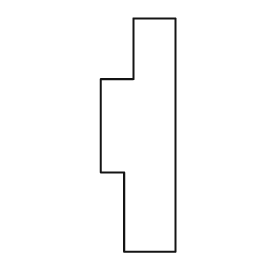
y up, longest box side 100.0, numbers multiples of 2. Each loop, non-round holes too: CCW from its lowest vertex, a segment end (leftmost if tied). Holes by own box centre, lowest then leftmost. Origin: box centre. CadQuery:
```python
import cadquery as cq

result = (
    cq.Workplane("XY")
    .moveTo(-6.0, -50.0)
    .lineTo(16.0, -50.0)
    .lineTo(16.0, 50.0)
    .lineTo(-2.0, 50.0)
    .lineTo(-2.0, 24.0)
    .lineTo(-16.0, 24.0)
    .lineTo(-16.0, -16.0)
    .lineTo(-6.0, -16.0)
    .close()
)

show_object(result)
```